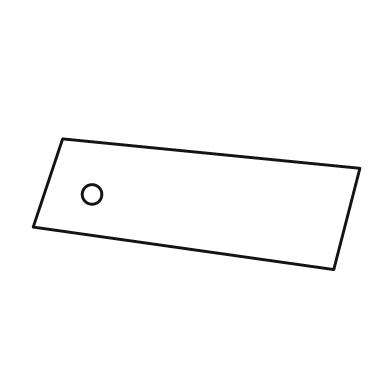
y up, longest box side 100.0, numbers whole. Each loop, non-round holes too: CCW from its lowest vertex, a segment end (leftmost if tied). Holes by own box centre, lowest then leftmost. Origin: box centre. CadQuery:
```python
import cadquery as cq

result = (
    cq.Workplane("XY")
    .moveTo(42.0, -20.0)
    .lineTo(50.0, 11.0)
    .lineTo(-41.0, 20.0)
    .lineTo(-50.0, -7.0)
    .close()
    .moveTo(-32.0, 3.0)
    .circle(3.0)
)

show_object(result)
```